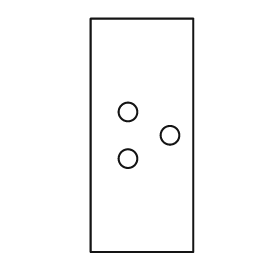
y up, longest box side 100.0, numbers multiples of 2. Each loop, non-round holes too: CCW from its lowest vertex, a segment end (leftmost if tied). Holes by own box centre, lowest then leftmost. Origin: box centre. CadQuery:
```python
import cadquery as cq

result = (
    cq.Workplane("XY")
    .moveTo(-22.0, -50.0)
    .lineTo(22.0, -50.0)
    .lineTo(22.0, 50.0)
    .lineTo(-22.0, 50.0)
    .close()
    .moveTo(-6.0, -10.0)
    .circle(4.0)
    .moveTo(12.0, 0.0)
    .circle(4.0)
    .moveTo(-6.0, 10.0)
    .circle(4.0)
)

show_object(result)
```